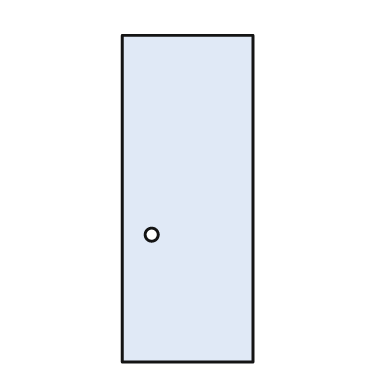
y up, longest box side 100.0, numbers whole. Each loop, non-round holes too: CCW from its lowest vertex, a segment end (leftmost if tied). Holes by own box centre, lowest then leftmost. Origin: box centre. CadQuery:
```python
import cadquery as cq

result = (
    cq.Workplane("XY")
    .moveTo(-20.0, -50.0)
    .lineTo(20.0, -50.0)
    .lineTo(20.0, 50.0)
    .lineTo(-20.0, 50.0)
    .close()
    .moveTo(-11.0, -11.0)
    .circle(2.0)
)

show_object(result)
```